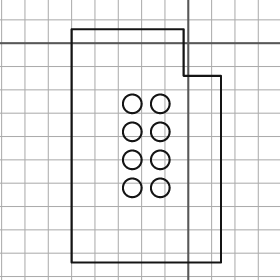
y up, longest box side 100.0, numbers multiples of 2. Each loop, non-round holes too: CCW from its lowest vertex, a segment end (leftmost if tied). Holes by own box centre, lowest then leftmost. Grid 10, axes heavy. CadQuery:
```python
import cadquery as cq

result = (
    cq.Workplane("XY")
    .moveTo(-50.0, -94.0)
    .lineTo(14.0, -94.0)
    .lineTo(14.0, -14.0)
    .lineTo(-2.0, -14.0)
    .lineTo(-2.0, 6.0)
    .lineTo(-50.0, 6.0)
    .close()
    .moveTo(-24.0, -62.0)
    .circle(4.0)
    .moveTo(-12.0, -62.0)
    .circle(4.0)
    .moveTo(-24.0, -50.0)
    .circle(4.0)
    .moveTo(-12.0, -50.0)
    .circle(4.0)
    .moveTo(-24.0, -38.0)
    .circle(4.0)
    .moveTo(-12.0, -38.0)
    .circle(4.0)
    .moveTo(-24.0, -26.0)
    .circle(4.0)
    .moveTo(-12.0, -26.0)
    .circle(4.0)
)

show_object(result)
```